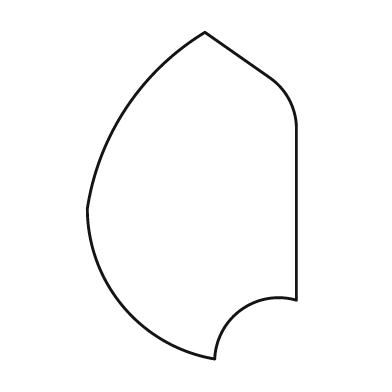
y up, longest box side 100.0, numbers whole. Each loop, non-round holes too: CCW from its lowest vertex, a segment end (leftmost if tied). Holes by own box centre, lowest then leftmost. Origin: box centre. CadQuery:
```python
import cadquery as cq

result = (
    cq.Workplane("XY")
    .moveTo(7.0, -50.0)
    .threePointArc((15.0, -35.0), (32.0, -32.0))
    .lineTo(32.0, 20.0)
    .threePointArc((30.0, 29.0), (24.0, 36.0))
    .lineTo(4.0, 50.0)
    .threePointArc((-20.0, 27.0), (-32.0, -4.0))
    .threePointArc((-21.0, -34.0), (7.0, -50.0))
    .close()
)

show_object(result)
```